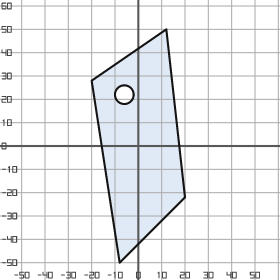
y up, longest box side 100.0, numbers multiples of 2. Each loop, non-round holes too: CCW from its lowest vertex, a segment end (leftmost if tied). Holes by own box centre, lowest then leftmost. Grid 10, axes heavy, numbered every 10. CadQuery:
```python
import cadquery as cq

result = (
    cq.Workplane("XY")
    .moveTo(-8.0, -50.0)
    .lineTo(20.0, -22.0)
    .lineTo(12.0, 50.0)
    .lineTo(-20.0, 28.0)
    .close()
    .moveTo(-6.0, 22.0)
    .circle(4.0)
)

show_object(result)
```